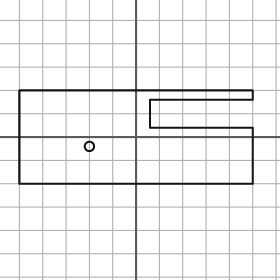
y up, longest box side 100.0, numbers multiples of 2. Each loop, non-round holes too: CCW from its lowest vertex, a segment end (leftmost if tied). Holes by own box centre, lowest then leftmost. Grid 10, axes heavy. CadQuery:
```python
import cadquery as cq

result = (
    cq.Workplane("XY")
    .moveTo(-50.0, -20.0)
    .lineTo(50.0, -20.0)
    .lineTo(50.0, 4.0)
    .lineTo(6.0, 4.0)
    .lineTo(6.0, 16.0)
    .lineTo(50.0, 16.0)
    .lineTo(50.0, 20.0)
    .lineTo(-50.0, 20.0)
    .close()
    .moveTo(-20.0, -4.0)
    .circle(2.0)
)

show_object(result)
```